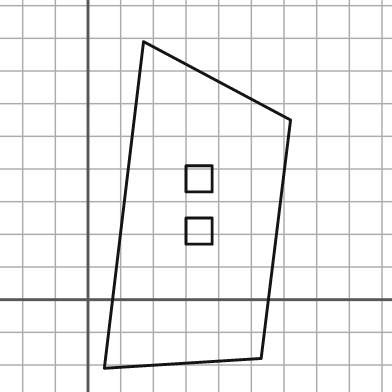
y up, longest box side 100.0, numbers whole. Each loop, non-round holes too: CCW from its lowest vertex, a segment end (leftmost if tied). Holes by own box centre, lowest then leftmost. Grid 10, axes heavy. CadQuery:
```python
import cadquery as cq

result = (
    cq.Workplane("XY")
    .moveTo(5.0, -21.0)
    .lineTo(53.0, -18.0)
    .lineTo(62.0, 55.0)
    .lineTo(17.0, 79.0)
    .close()
    .moveTo(30.0, 17.0)
    .lineTo(38.0, 17.0)
    .lineTo(38.0, 25.0)
    .lineTo(30.0, 25.0)
    .close()
    .moveTo(30.0, 33.0)
    .lineTo(38.0, 33.0)
    .lineTo(38.0, 41.0)
    .lineTo(30.0, 41.0)
    .close()
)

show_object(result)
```